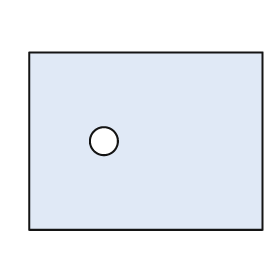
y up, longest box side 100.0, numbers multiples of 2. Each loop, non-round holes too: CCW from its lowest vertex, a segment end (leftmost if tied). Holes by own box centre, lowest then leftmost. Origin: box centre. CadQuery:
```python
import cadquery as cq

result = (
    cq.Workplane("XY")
    .moveTo(-50.0, -38.0)
    .lineTo(50.0, -38.0)
    .lineTo(50.0, 38.0)
    .lineTo(-50.0, 38.0)
    .close()
    .moveTo(-18.0, 0.0)
    .circle(6.0)
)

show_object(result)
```